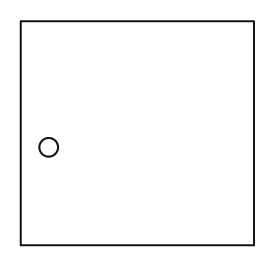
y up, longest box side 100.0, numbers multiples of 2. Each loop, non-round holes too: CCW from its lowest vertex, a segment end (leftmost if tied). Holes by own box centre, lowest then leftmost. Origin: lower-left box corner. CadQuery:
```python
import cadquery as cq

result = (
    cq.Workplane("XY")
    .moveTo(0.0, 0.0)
    .lineTo(100.0, 0.0)
    .lineTo(100.0, 96.0)
    .lineTo(0.0, 96.0)
    .close()
    .moveTo(12.0, 42.0)
    .circle(4.0)
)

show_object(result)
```